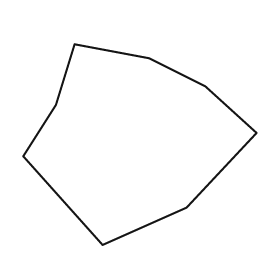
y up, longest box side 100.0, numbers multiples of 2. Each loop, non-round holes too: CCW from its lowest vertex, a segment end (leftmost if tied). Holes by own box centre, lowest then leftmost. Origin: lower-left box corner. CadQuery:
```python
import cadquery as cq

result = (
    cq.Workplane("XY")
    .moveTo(34.0, 0.0)
    .lineTo(70.0, 16.0)
    .lineTo(100.0, 48.0)
    .lineTo(78.0, 68.0)
    .lineTo(54.0, 80.0)
    .lineTo(22.0, 86.0)
    .lineTo(14.0, 60.0)
    .lineTo(0.0, 38.0)
    .close()
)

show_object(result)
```